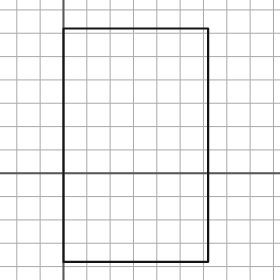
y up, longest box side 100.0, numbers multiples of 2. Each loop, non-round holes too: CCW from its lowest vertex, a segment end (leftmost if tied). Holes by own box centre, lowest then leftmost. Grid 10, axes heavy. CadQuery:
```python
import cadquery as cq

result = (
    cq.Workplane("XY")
    .moveTo(0.0, -38.0)
    .lineTo(62.0, -38.0)
    .lineTo(62.0, 62.0)
    .lineTo(0.0, 62.0)
    .close()
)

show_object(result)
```